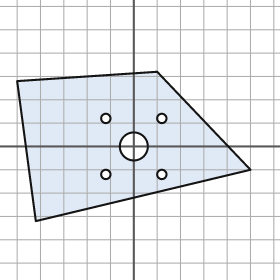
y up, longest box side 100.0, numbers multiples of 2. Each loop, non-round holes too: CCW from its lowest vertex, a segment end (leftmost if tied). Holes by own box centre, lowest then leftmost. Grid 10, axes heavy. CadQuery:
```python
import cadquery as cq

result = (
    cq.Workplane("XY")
    .moveTo(-42.0, -32.0)
    .lineTo(50.0, -10.0)
    .lineTo(10.0, 32.0)
    .lineTo(-50.0, 28.0)
    .close()
    .moveTo(-12.0, -12.0)
    .circle(2.0)
    .moveTo(12.0, -12.0)
    .circle(2.0)
    .moveTo(0.0, 0.0)
    .circle(6.0)
    .moveTo(-12.0, 12.0)
    .circle(2.0)
    .moveTo(12.0, 12.0)
    .circle(2.0)
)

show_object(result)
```